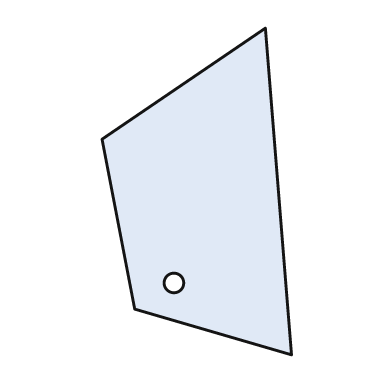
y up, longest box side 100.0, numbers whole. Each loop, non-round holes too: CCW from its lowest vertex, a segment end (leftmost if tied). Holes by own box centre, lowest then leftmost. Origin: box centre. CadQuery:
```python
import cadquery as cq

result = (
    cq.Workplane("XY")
    .moveTo(29.0, -50.0)
    .lineTo(21.0, 50.0)
    .lineTo(-29.0, 16.0)
    .lineTo(-19.0, -36.0)
    .close()
    .moveTo(-7.0, -28.0)
    .circle(3.0)
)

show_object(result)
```